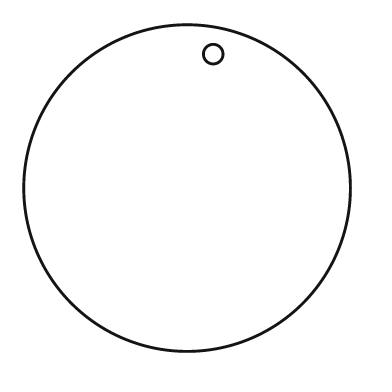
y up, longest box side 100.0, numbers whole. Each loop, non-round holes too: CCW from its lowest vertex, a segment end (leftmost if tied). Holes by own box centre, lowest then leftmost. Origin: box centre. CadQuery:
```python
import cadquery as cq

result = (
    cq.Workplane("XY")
    .moveTo(0.0, 0.0)
    .circle(50.0)
    .moveTo(8.0, 41.0)
    .circle(3.0)
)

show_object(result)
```